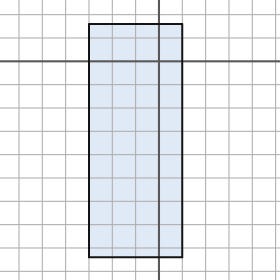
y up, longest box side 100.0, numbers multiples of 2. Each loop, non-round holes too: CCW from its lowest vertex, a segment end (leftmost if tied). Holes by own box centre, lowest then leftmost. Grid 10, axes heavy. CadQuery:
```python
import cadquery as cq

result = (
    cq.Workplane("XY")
    .moveTo(-30.0, -84.0)
    .lineTo(10.0, -84.0)
    .lineTo(10.0, 16.0)
    .lineTo(-30.0, 16.0)
    .close()
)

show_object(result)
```